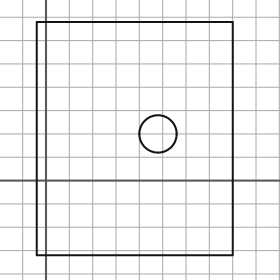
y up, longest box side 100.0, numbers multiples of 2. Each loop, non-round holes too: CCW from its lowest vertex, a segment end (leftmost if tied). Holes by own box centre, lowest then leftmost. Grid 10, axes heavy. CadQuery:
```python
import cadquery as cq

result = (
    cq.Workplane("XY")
    .moveTo(-4.0, -32.0)
    .lineTo(80.0, -32.0)
    .lineTo(80.0, 68.0)
    .lineTo(-4.0, 68.0)
    .close()
    .moveTo(48.0, 20.0)
    .circle(8.0)
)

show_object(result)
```